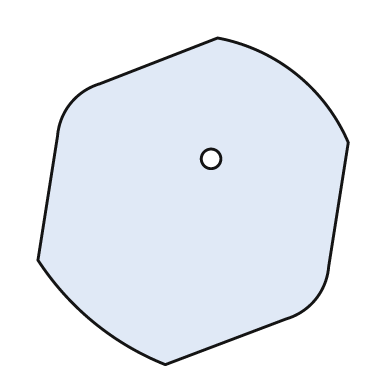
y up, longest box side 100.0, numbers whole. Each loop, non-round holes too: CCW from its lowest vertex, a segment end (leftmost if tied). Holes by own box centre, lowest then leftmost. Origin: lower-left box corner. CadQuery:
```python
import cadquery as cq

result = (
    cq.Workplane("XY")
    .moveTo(39.0, 0.0)
    .lineTo(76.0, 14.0)
    .threePointArc((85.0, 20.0), (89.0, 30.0))
    .lineTo(95.0, 68.0)
    .threePointArc((79.0, 89.0), (55.0, 100.0))
    .lineTo(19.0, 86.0)
    .threePointArc((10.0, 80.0), (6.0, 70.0))
    .lineTo(0.0, 32.0)
    .threePointArc((17.0, 13.0), (39.0, 0.0))
    .close()
    .moveTo(53.0, 63.0)
    .circle(3.0)
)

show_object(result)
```